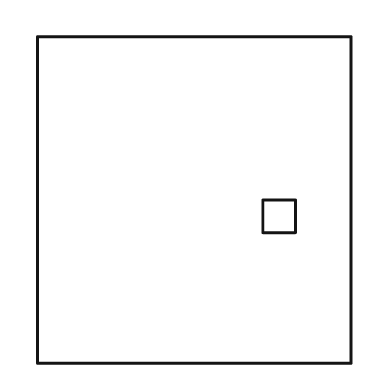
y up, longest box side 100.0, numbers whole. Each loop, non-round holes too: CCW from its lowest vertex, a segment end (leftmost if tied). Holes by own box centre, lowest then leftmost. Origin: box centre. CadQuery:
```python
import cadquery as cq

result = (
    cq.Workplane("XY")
    .moveTo(-48.0, -50.0)
    .lineTo(48.0, -50.0)
    .lineTo(48.0, 50.0)
    .lineTo(-48.0, 50.0)
    .close()
    .moveTo(21.0, -10.0)
    .lineTo(31.0, -10.0)
    .lineTo(31.0, 0.0)
    .lineTo(21.0, 0.0)
    .close()
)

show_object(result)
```